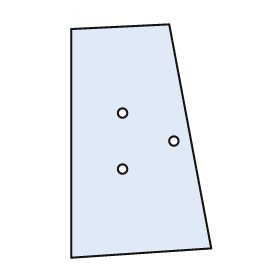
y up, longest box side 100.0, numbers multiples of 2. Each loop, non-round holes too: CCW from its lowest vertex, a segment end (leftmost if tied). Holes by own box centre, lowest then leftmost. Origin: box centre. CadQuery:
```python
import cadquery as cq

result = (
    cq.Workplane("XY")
    .moveTo(-30.0, -50.0)
    .lineTo(30.0, -46.0)
    .lineTo(12.0, 50.0)
    .lineTo(-30.0, 48.0)
    .close()
    .moveTo(-8.0, -12.0)
    .circle(2.0)
    .moveTo(14.0, 0.0)
    .circle(2.0)
    .moveTo(-8.0, 12.0)
    .circle(2.0)
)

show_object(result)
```